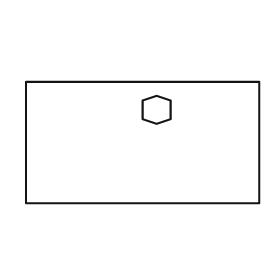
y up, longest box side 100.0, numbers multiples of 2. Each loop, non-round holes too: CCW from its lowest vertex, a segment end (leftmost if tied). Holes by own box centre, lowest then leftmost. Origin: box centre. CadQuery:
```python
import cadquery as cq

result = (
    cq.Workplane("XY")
    .moveTo(-50.0, -26.0)
    .lineTo(50.0, -26.0)
    .lineTo(50.0, 26.0)
    .lineTo(-50.0, 26.0)
    .close()
    .moveTo(6.0, 8.0)
    .lineTo(12.0, 10.0)
    .lineTo(12.0, 18.0)
    .lineTo(6.0, 20.0)
    .lineTo(0.0, 18.0)
    .lineTo(0.0, 10.0)
    .close()
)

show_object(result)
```